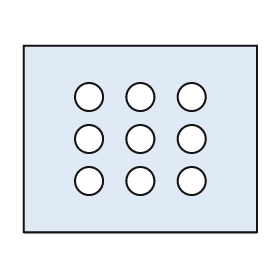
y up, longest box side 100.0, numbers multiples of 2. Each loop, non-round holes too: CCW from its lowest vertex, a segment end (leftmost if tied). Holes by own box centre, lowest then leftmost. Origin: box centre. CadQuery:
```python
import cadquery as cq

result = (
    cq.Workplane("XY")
    .moveTo(-50.0, -40.0)
    .lineTo(50.0, -40.0)
    .lineTo(50.0, 40.0)
    .lineTo(-50.0, 40.0)
    .close()
    .moveTo(-22.0, -18.0)
    .circle(6.0)
    .moveTo(0.0, -18.0)
    .circle(6.0)
    .moveTo(22.0, -18.0)
    .circle(6.0)
    .moveTo(-22.0, 0.0)
    .circle(6.0)
    .moveTo(0.0, 0.0)
    .circle(6.0)
    .moveTo(22.0, 0.0)
    .circle(6.0)
    .moveTo(-22.0, 18.0)
    .circle(6.0)
    .moveTo(0.0, 18.0)
    .circle(6.0)
    .moveTo(22.0, 18.0)
    .circle(6.0)
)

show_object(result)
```